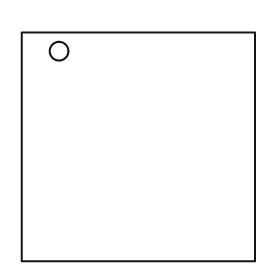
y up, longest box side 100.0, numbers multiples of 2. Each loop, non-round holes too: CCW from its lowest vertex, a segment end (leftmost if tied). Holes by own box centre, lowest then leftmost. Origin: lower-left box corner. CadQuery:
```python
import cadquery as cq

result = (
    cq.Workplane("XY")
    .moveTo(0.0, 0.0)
    .lineTo(100.0, 0.0)
    .lineTo(100.0, 98.0)
    .lineTo(0.0, 98.0)
    .close()
    .moveTo(16.0, 90.0)
    .circle(4.0)
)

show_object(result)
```